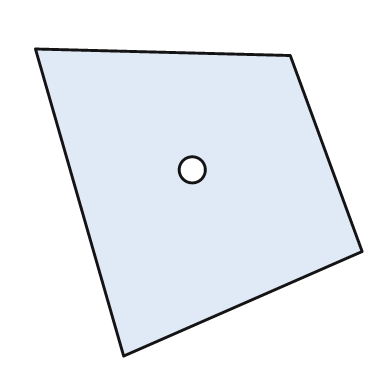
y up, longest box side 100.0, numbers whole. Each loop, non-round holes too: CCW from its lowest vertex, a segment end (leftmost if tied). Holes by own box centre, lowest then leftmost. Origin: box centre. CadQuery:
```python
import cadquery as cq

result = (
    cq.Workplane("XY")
    .moveTo(-23.0, -47.0)
    .lineTo(50.0, -15.0)
    .lineTo(28.0, 45.0)
    .lineTo(-50.0, 47.0)
    .close()
    .moveTo(-2.0, 10.0)
    .circle(4.0)
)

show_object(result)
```